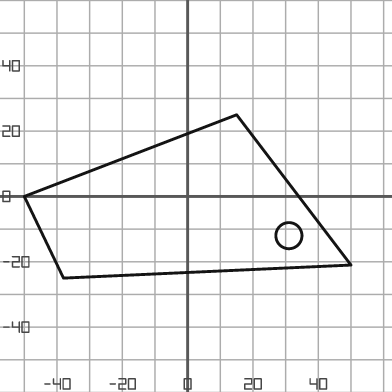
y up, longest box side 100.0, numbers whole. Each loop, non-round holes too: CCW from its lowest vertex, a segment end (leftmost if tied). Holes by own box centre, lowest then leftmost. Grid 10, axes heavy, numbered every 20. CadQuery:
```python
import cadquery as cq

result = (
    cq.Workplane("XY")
    .moveTo(-38.0, -25.0)
    .lineTo(50.0, -21.0)
    .lineTo(15.0, 25.0)
    .lineTo(-50.0, 0.0)
    .close()
    .moveTo(31.0, -12.0)
    .circle(4.0)
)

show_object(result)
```